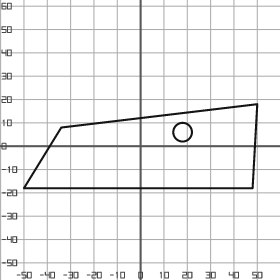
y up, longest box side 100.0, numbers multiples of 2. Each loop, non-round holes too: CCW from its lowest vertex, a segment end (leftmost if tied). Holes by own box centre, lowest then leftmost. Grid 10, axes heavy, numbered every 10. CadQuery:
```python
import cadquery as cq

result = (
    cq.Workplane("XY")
    .moveTo(-50.0, -18.0)
    .lineTo(48.0, -18.0)
    .lineTo(50.0, 18.0)
    .lineTo(-34.0, 8.0)
    .close()
    .moveTo(18.0, 6.0)
    .circle(4.0)
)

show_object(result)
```